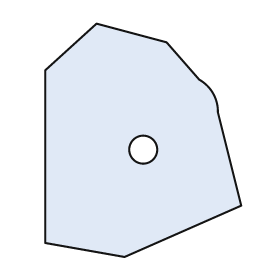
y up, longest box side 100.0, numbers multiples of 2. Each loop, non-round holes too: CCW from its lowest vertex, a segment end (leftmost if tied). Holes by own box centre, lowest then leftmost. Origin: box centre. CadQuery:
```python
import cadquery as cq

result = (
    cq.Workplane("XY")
    .moveTo(-8.0, -50.0)
    .lineTo(42.0, -28.0)
    .lineTo(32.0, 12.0)
    .threePointArc((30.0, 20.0), (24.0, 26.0))
    .lineTo(10.0, 42.0)
    .lineTo(-20.0, 50.0)
    .lineTo(-42.0, 30.0)
    .lineTo(-42.0, -44.0)
    .close()
    .moveTo(0.0, -4.0)
    .circle(6.0)
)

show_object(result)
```